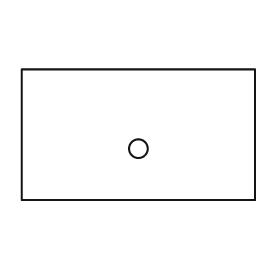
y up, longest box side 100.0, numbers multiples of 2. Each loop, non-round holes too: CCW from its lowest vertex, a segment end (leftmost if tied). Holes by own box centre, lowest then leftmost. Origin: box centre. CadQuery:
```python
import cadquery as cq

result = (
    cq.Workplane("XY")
    .moveTo(-50.0, -28.0)
    .lineTo(50.0, -28.0)
    .lineTo(50.0, 28.0)
    .lineTo(-50.0, 28.0)
    .close()
    .moveTo(0.0, -6.0)
    .circle(4.0)
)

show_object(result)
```